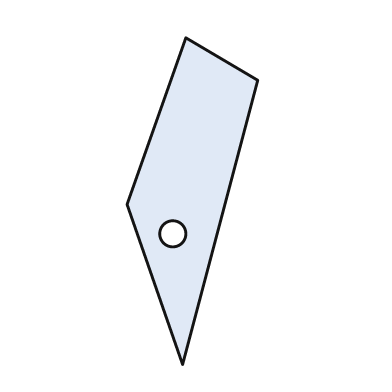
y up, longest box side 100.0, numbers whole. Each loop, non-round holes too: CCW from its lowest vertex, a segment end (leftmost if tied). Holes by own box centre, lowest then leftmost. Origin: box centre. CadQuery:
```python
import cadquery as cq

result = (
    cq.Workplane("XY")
    .moveTo(-3.0, -50.0)
    .lineTo(20.0, 37.0)
    .lineTo(-2.0, 50.0)
    .lineTo(-20.0, -1.0)
    .close()
    .moveTo(-6.0, -10.0)
    .circle(4.0)
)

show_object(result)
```